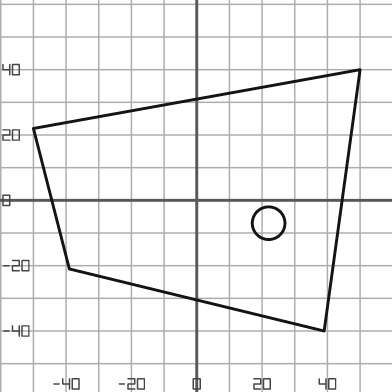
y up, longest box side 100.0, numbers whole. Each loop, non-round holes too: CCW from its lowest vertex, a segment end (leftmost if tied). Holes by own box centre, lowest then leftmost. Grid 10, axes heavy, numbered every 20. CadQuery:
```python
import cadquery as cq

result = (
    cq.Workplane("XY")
    .moveTo(39.0, -40.0)
    .lineTo(50.0, 40.0)
    .lineTo(-50.0, 22.0)
    .lineTo(-39.0, -21.0)
    .close()
    .moveTo(22.0, -7.0)
    .circle(5.0)
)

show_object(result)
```